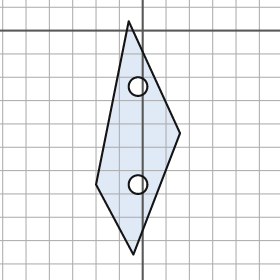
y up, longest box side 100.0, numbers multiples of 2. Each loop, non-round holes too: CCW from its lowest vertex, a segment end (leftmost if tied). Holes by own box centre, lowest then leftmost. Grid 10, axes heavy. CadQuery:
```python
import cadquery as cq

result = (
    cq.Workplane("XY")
    .moveTo(-4.0, -96.0)
    .lineTo(16.0, -44.0)
    .lineTo(-6.0, 4.0)
    .lineTo(-20.0, -66.0)
    .close()
    .moveTo(-2.0, -66.0)
    .circle(4.0)
    .moveTo(-2.0, -24.0)
    .circle(4.0)
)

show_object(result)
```